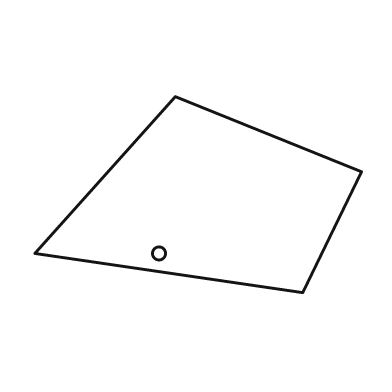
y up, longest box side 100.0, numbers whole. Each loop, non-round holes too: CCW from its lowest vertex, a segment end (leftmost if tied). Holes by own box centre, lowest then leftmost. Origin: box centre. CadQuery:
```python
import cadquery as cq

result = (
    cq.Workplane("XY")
    .moveTo(32.0, -30.0)
    .lineTo(50.0, 7.0)
    .lineTo(-7.0, 30.0)
    .lineTo(-50.0, -18.0)
    .close()
    .moveTo(-12.0, -18.0)
    .circle(2.0)
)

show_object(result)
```